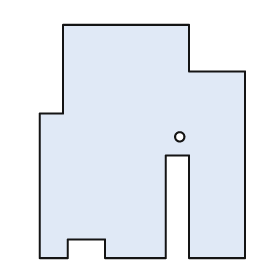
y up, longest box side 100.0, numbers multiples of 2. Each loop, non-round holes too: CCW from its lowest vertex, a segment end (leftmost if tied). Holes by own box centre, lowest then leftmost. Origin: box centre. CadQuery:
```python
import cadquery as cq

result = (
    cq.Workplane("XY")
    .moveTo(-44.0, -50.0)
    .lineTo(-32.0, -50.0)
    .lineTo(-32.0, -42.0)
    .lineTo(-16.0, -42.0)
    .lineTo(-16.0, -50.0)
    .lineTo(10.0, -50.0)
    .lineTo(10.0, -6.0)
    .lineTo(20.0, -6.0)
    .lineTo(20.0, -50.0)
    .lineTo(44.0, -50.0)
    .lineTo(44.0, 30.0)
    .lineTo(20.0, 30.0)
    .lineTo(20.0, 50.0)
    .lineTo(-34.0, 50.0)
    .lineTo(-34.0, 12.0)
    .lineTo(-44.0, 12.0)
    .close()
    .moveTo(16.0, 2.0)
    .circle(2.0)
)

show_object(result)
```